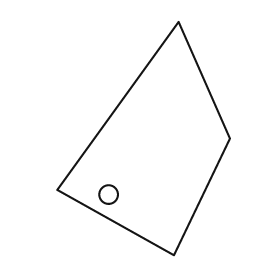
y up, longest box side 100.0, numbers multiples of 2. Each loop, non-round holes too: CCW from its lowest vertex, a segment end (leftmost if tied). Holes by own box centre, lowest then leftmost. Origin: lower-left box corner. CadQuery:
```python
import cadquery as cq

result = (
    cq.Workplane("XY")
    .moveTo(50.0, 0.0)
    .lineTo(74.0, 50.0)
    .lineTo(52.0, 100.0)
    .lineTo(0.0, 28.0)
    .close()
    .moveTo(22.0, 26.0)
    .circle(4.0)
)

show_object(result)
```